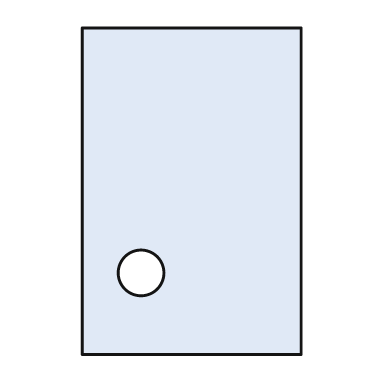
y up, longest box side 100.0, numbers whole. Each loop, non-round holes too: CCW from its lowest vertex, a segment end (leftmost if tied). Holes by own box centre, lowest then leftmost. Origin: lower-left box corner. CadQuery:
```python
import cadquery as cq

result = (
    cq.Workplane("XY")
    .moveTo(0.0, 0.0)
    .lineTo(67.0, 0.0)
    .lineTo(67.0, 100.0)
    .lineTo(0.0, 100.0)
    .close()
    .moveTo(18.0, 25.0)
    .circle(7.0)
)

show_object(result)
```